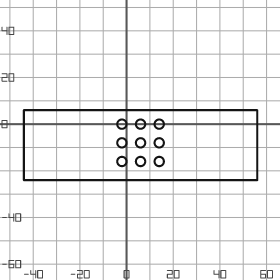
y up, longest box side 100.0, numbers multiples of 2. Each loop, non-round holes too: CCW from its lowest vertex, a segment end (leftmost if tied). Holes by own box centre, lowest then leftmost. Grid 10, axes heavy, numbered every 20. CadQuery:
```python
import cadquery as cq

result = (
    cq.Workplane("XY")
    .moveTo(-44.0, -24.0)
    .lineTo(56.0, -24.0)
    .lineTo(56.0, 6.0)
    .lineTo(-44.0, 6.0)
    .close()
    .moveTo(-2.0, -16.0)
    .circle(2.0)
    .moveTo(6.0, -16.0)
    .circle(2.0)
    .moveTo(14.0, -16.0)
    .circle(2.0)
    .moveTo(-2.0, -8.0)
    .circle(2.0)
    .moveTo(6.0, -8.0)
    .circle(2.0)
    .moveTo(14.0, -8.0)
    .circle(2.0)
    .moveTo(-2.0, 0.0)
    .circle(2.0)
    .moveTo(6.0, 0.0)
    .circle(2.0)
    .moveTo(14.0, 0.0)
    .circle(2.0)
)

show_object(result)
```